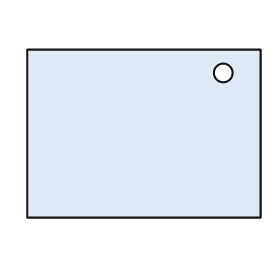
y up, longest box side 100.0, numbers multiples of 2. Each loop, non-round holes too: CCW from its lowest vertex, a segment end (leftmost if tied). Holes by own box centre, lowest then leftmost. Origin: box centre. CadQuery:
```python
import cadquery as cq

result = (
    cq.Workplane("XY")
    .moveTo(-50.0, -36.0)
    .lineTo(50.0, -36.0)
    .lineTo(50.0, 36.0)
    .lineTo(-50.0, 36.0)
    .close()
    .moveTo(34.0, 26.0)
    .circle(4.0)
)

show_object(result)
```